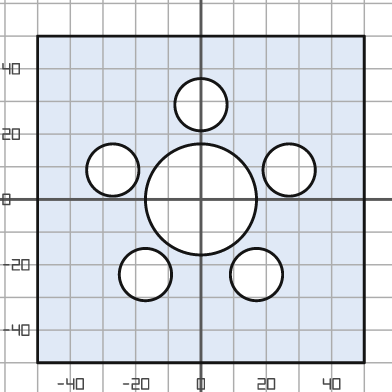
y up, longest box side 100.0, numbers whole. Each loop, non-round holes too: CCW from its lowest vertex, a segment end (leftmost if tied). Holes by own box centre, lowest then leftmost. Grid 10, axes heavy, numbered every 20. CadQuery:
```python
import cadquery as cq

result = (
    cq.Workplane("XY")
    .moveTo(-50.0, -50.0)
    .lineTo(50.0, -50.0)
    .lineTo(50.0, 50.0)
    .lineTo(-50.0, 50.0)
    .close()
    .moveTo(-17.0, -23.0)
    .circle(8.0)
    .moveTo(17.0, -23.0)
    .circle(8.0)
    .moveTo(0.0, 0.0)
    .circle(17.0)
    .moveTo(-27.0, 9.0)
    .circle(8.0)
    .moveTo(27.0, 9.0)
    .circle(8.0)
    .moveTo(0.0, 29.0)
    .circle(8.0)
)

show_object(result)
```